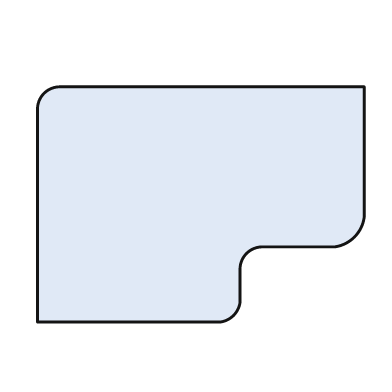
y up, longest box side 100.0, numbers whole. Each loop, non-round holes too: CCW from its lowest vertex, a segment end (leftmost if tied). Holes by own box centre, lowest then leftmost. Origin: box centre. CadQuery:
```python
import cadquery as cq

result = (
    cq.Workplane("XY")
    .moveTo(-50.0, -36.0)
    .lineTo(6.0, -36.0)
    .threePointArc((10.0, -34.0), (12.0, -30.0))
    .lineTo(12.0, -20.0)
    .threePointArc((14.0, -15.0), (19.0, -13.0))
    .lineTo(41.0, -13.0)
    .threePointArc((47.0, -10.0), (50.0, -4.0))
    .lineTo(50.0, 36.0)
    .lineTo(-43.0, 36.0)
    .threePointArc((-48.0, 34.0), (-50.0, 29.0))
    .close()
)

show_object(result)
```